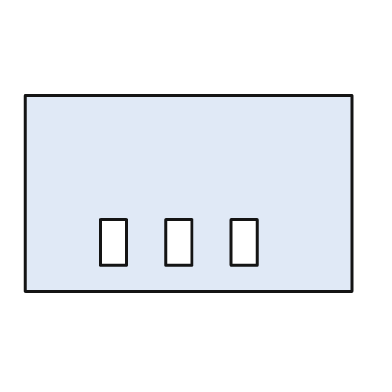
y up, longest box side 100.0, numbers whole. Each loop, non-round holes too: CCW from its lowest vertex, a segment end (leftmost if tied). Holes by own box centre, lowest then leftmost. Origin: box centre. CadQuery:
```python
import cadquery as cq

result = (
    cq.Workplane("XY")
    .moveTo(-50.0, -30.0)
    .lineTo(50.0, -30.0)
    .lineTo(50.0, 30.0)
    .lineTo(-50.0, 30.0)
    .close()
    .moveTo(-27.0, -22.0)
    .lineTo(-19.0, -22.0)
    .lineTo(-19.0, -8.0)
    .lineTo(-27.0, -8.0)
    .close()
    .moveTo(-7.0, -22.0)
    .lineTo(1.0, -22.0)
    .lineTo(1.0, -8.0)
    .lineTo(-7.0, -8.0)
    .close()
    .moveTo(13.0, -22.0)
    .lineTo(21.0, -22.0)
    .lineTo(21.0, -8.0)
    .lineTo(13.0, -8.0)
    .close()
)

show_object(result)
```